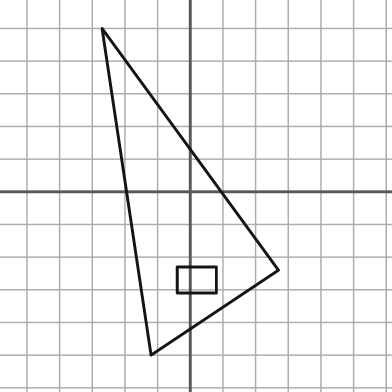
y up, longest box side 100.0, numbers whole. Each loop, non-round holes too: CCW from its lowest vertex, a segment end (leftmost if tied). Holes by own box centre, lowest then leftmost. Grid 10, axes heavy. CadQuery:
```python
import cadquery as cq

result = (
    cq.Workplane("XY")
    .moveTo(-12.0, -50.0)
    .lineTo(27.0, -24.0)
    .lineTo(-27.0, 50.0)
    .close()
    .moveTo(-4.0, -31.0)
    .lineTo(8.0, -31.0)
    .lineTo(8.0, -23.0)
    .lineTo(-4.0, -23.0)
    .close()
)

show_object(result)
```